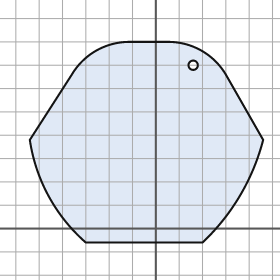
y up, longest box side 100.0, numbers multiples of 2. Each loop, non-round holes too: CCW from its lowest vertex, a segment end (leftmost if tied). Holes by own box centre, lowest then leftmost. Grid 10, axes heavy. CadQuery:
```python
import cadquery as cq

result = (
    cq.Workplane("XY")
    .moveTo(-30.0, -6.0)
    .lineTo(20.0, -6.0)
    .threePointArc((36.0, 14.0), (46.0, 38.0))
    .lineTo(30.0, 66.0)
    .threePointArc((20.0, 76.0), (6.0, 80.0))
    .lineTo(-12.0, 80.0)
    .threePointArc((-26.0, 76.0), (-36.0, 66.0))
    .lineTo(-54.0, 38.0)
    .threePointArc((-46.0, 14.0), (-30.0, -6.0))
    .close()
    .moveTo(16.0, 70.0)
    .circle(2.0)
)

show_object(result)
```